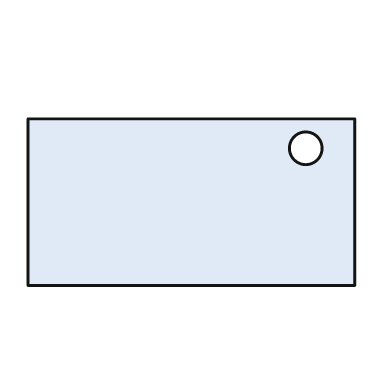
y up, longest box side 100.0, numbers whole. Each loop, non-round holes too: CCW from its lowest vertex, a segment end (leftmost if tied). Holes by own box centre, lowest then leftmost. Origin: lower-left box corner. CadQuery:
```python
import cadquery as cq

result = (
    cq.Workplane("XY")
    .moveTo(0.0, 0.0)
    .lineTo(100.0, 0.0)
    .lineTo(100.0, 51.0)
    .lineTo(0.0, 51.0)
    .close()
    .moveTo(85.0, 42.0)
    .circle(5.0)
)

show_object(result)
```